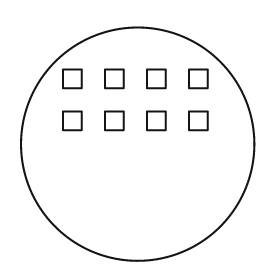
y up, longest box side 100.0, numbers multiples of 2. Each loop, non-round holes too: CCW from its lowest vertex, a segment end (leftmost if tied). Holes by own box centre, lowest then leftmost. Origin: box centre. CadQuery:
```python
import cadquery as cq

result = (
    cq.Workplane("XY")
    .moveTo(0.0, 0.0)
    .circle(50.0)
    .moveTo(-32.0, 6.0)
    .lineTo(-24.0, 6.0)
    .lineTo(-24.0, 14.0)
    .lineTo(-32.0, 14.0)
    .close()
    .moveTo(-14.0, 6.0)
    .lineTo(-6.0, 6.0)
    .lineTo(-6.0, 14.0)
    .lineTo(-14.0, 14.0)
    .close()
    .moveTo(4.0, 6.0)
    .lineTo(12.0, 6.0)
    .lineTo(12.0, 14.0)
    .lineTo(4.0, 14.0)
    .close()
    .moveTo(22.0, 6.0)
    .lineTo(30.0, 6.0)
    .lineTo(30.0, 14.0)
    .lineTo(22.0, 14.0)
    .close()
    .moveTo(-32.0, 24.0)
    .lineTo(-24.0, 24.0)
    .lineTo(-24.0, 32.0)
    .lineTo(-32.0, 32.0)
    .close()
    .moveTo(-14.0, 24.0)
    .lineTo(-6.0, 24.0)
    .lineTo(-6.0, 32.0)
    .lineTo(-14.0, 32.0)
    .close()
    .moveTo(4.0, 24.0)
    .lineTo(12.0, 24.0)
    .lineTo(12.0, 32.0)
    .lineTo(4.0, 32.0)
    .close()
    .moveTo(22.0, 24.0)
    .lineTo(30.0, 24.0)
    .lineTo(30.0, 32.0)
    .lineTo(22.0, 32.0)
    .close()
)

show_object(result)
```